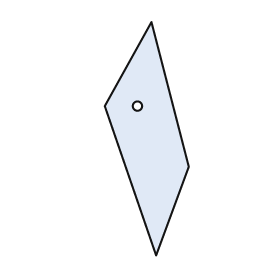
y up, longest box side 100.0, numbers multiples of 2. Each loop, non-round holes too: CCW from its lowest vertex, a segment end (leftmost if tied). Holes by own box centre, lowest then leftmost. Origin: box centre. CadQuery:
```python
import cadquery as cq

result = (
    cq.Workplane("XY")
    .moveTo(4.0, -50.0)
    .lineTo(18.0, -12.0)
    .lineTo(2.0, 50.0)
    .lineTo(-18.0, 14.0)
    .close()
    .moveTo(-4.0, 14.0)
    .circle(2.0)
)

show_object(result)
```